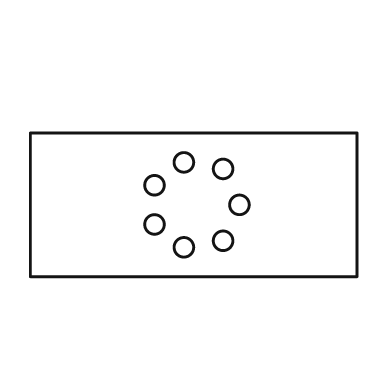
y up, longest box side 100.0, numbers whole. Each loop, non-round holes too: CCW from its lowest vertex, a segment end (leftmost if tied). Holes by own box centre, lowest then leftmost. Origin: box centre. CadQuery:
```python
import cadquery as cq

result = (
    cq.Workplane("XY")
    .moveTo(-50.0, -22.0)
    .lineTo(50.0, -22.0)
    .lineTo(50.0, 22.0)
    .lineTo(-50.0, 22.0)
    .close()
    .moveTo(-3.0, -13.0)
    .circle(3.0)
    .moveTo(9.0, -11.0)
    .circle(3.0)
    .moveTo(-12.0, -6.0)
    .circle(3.0)
    .moveTo(14.0, 0.0)
    .circle(3.0)
    .moveTo(-12.0, 6.0)
    .circle(3.0)
    .moveTo(9.0, 11.0)
    .circle(3.0)
    .moveTo(-3.0, 13.0)
    .circle(3.0)
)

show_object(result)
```